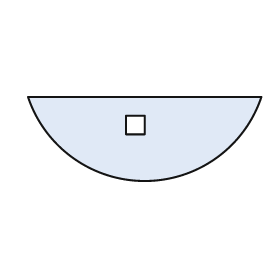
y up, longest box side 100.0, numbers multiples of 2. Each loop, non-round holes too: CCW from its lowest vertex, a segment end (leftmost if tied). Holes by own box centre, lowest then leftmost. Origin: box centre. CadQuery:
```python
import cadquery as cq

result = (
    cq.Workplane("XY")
    .moveTo(-50.0, 18.0)
    .threePointArc((0.0, -18.0), (50.0, 18.0))
    .close()
    .moveTo(-8.0, 2.0)
    .lineTo(0.0, 2.0)
    .lineTo(0.0, 10.0)
    .lineTo(-8.0, 10.0)
    .close()
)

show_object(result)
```